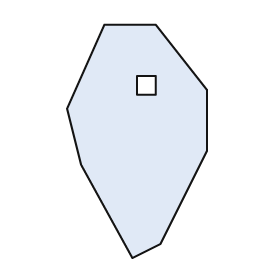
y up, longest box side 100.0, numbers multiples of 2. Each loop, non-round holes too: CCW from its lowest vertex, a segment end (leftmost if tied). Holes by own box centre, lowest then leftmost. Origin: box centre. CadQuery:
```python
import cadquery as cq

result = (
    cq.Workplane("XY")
    .moveTo(-2.0, -50.0)
    .lineTo(10.0, -44.0)
    .lineTo(30.0, -4.0)
    .lineTo(30.0, 22.0)
    .lineTo(8.0, 50.0)
    .lineTo(-14.0, 50.0)
    .lineTo(-30.0, 14.0)
    .lineTo(-24.0, -10.0)
    .close()
    .moveTo(0.0, 20.0)
    .lineTo(8.0, 20.0)
    .lineTo(8.0, 28.0)
    .lineTo(0.0, 28.0)
    .close()
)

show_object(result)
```